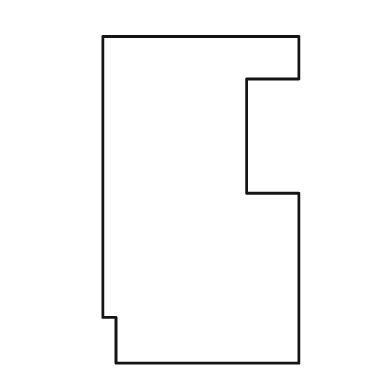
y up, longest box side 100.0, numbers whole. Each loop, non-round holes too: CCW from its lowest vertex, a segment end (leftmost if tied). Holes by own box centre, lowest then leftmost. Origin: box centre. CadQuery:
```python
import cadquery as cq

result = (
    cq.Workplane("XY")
    .moveTo(-26.0, -50.0)
    .lineTo(30.0, -50.0)
    .lineTo(30.0, 2.0)
    .lineTo(14.0, 2.0)
    .lineTo(14.0, 37.0)
    .lineTo(30.0, 37.0)
    .lineTo(30.0, 50.0)
    .lineTo(-30.0, 50.0)
    .lineTo(-30.0, -36.0)
    .lineTo(-26.0, -36.0)
    .close()
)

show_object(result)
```